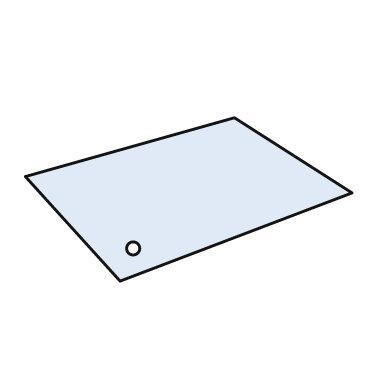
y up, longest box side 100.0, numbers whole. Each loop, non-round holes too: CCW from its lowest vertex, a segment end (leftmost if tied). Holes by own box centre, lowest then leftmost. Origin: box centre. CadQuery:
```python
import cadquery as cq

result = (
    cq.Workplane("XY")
    .moveTo(-21.0, -25.0)
    .lineTo(50.0, 2.0)
    .lineTo(14.0, 25.0)
    .lineTo(-50.0, 7.0)
    .close()
    .moveTo(-17.0, -15.0)
    .circle(2.0)
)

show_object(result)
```